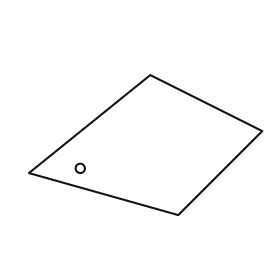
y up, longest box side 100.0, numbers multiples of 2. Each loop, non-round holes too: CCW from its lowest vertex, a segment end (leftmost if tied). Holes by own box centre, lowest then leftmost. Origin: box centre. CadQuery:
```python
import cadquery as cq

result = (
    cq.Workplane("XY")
    .moveTo(14.0, -30.0)
    .lineTo(50.0, 6.0)
    .lineTo(2.0, 30.0)
    .lineTo(-50.0, -12.0)
    .close()
    .moveTo(-28.0, -10.0)
    .circle(2.0)
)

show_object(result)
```